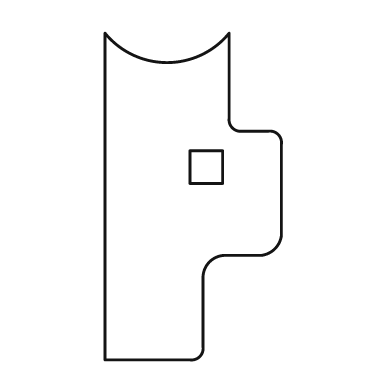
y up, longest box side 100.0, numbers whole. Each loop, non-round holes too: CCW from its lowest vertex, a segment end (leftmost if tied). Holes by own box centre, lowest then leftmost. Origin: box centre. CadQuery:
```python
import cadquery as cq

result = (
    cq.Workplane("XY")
    .moveTo(-27.0, -50.0)
    .lineTo(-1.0, -50.0)
    .threePointArc((2.0, -49.0), (3.0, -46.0))
    .lineTo(3.0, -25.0)
    .threePointArc((5.0, -20.0), (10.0, -18.0))
    .lineTo(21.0, -18.0)
    .threePointArc((25.0, -16.0), (27.0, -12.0))
    .lineTo(27.0, 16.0)
    .threePointArc((26.0, 19.0), (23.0, 20.0))
    .lineTo(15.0, 20.0)
    .threePointArc((12.0, 21.0), (11.0, 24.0))
    .lineTo(11.0, 50.0)
    .threePointArc((-8.0, 41.0), (-27.0, 50.0))
    .close()
    .moveTo(-1.0, 4.0)
    .lineTo(9.0, 4.0)
    .lineTo(9.0, 14.0)
    .lineTo(-1.0, 14.0)
    .close()
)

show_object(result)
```